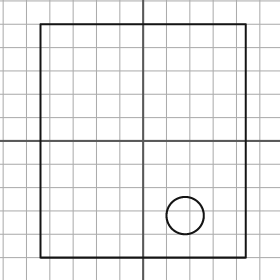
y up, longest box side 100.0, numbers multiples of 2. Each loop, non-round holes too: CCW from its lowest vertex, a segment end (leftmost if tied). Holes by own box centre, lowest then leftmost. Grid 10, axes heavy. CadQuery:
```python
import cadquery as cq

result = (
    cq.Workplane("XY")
    .moveTo(-44.0, -50.0)
    .lineTo(44.0, -50.0)
    .lineTo(44.0, 50.0)
    .lineTo(-44.0, 50.0)
    .close()
    .moveTo(18.0, -32.0)
    .circle(8.0)
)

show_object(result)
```